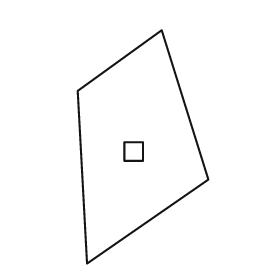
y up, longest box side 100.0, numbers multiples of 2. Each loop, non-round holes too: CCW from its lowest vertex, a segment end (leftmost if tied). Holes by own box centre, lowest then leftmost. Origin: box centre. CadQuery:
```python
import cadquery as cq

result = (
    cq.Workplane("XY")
    .moveTo(-24.0, -50.0)
    .lineTo(28.0, -14.0)
    .lineTo(8.0, 50.0)
    .lineTo(-28.0, 24.0)
    .close()
    .moveTo(-8.0, -6.0)
    .lineTo(0.0, -6.0)
    .lineTo(0.0, 2.0)
    .lineTo(-8.0, 2.0)
    .close()
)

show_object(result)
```